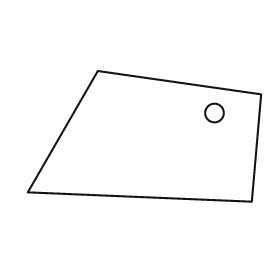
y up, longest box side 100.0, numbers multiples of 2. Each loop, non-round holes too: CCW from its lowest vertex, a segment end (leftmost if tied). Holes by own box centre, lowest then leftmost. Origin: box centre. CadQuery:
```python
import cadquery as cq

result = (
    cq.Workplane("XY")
    .moveTo(46.0, -28.0)
    .lineTo(50.0, 18.0)
    .lineTo(-20.0, 28.0)
    .lineTo(-50.0, -24.0)
    .close()
    .moveTo(30.0, 10.0)
    .circle(4.0)
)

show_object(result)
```